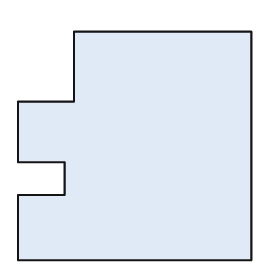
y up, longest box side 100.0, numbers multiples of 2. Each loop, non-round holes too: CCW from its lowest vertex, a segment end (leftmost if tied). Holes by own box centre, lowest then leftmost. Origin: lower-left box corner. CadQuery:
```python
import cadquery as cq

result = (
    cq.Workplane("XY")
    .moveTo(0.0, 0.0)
    .lineTo(100.0, 0.0)
    .lineTo(100.0, 98.0)
    .lineTo(24.0, 98.0)
    .lineTo(24.0, 68.0)
    .lineTo(0.0, 68.0)
    .lineTo(0.0, 42.0)
    .lineTo(20.0, 42.0)
    .lineTo(20.0, 28.0)
    .lineTo(0.0, 28.0)
    .close()
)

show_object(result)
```